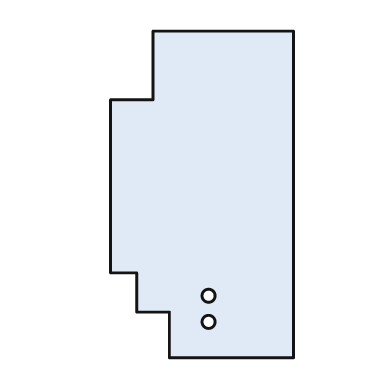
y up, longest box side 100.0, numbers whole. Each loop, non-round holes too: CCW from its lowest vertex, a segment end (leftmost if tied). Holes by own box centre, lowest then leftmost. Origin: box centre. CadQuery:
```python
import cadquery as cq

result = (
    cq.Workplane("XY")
    .moveTo(-10.0, -50.0)
    .lineTo(28.0, -50.0)
    .lineTo(28.0, 50.0)
    .lineTo(-15.0, 50.0)
    .lineTo(-15.0, 29.0)
    .lineTo(-28.0, 29.0)
    .lineTo(-28.0, -24.0)
    .lineTo(-20.0, -24.0)
    .lineTo(-20.0, -36.0)
    .lineTo(-10.0, -36.0)
    .close()
    .moveTo(2.0, -39.0)
    .circle(2.0)
    .moveTo(2.0, -31.0)
    .circle(2.0)
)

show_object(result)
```